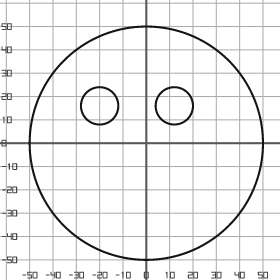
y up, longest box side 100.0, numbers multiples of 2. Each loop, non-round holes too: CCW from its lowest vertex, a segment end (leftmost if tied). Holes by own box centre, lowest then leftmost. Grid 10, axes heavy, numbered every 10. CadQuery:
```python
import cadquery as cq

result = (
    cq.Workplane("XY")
    .moveTo(0.0, 0.0)
    .circle(50.0)
    .moveTo(-20.0, 16.0)
    .circle(8.0)
    .moveTo(12.0, 16.0)
    .circle(8.0)
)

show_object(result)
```